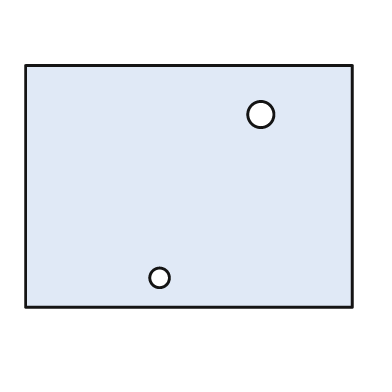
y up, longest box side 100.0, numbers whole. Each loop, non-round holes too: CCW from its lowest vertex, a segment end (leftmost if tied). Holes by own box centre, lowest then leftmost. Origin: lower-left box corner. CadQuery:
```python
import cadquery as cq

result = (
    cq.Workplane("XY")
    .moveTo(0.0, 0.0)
    .lineTo(100.0, 0.0)
    .lineTo(100.0, 74.0)
    .lineTo(0.0, 74.0)
    .close()
    .moveTo(41.0, 9.0)
    .circle(3.0)
    .moveTo(72.0, 59.0)
    .circle(4.0)
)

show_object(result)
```